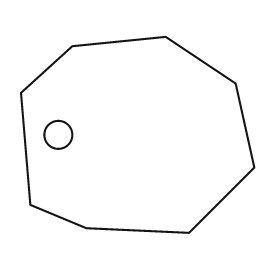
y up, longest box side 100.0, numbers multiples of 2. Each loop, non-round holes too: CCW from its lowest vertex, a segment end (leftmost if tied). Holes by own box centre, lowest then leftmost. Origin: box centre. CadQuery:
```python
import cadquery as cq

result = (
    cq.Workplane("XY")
    .moveTo(22.0, -42.0)
    .lineTo(50.0, -14.0)
    .lineTo(42.0, 22.0)
    .lineTo(12.0, 42.0)
    .lineTo(-28.0, 38.0)
    .lineTo(-50.0, 18.0)
    .lineTo(-46.0, -30.0)
    .lineTo(-22.0, -40.0)
    .close()
    .moveTo(-34.0, 0.0)
    .circle(6.0)
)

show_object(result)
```